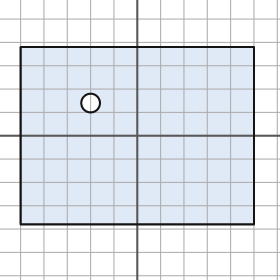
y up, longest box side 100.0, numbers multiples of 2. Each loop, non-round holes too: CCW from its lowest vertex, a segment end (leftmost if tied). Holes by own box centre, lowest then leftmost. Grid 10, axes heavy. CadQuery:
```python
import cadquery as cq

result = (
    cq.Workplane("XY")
    .moveTo(-50.0, -38.0)
    .lineTo(50.0, -38.0)
    .lineTo(50.0, 38.0)
    .lineTo(-50.0, 38.0)
    .close()
    .moveTo(-20.0, 14.0)
    .circle(4.0)
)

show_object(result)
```